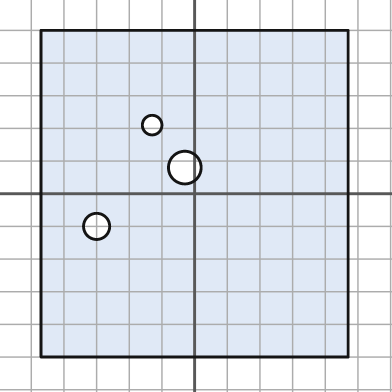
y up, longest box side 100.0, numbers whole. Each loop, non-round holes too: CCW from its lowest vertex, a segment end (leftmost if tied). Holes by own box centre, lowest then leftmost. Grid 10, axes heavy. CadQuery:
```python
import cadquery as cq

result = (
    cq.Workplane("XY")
    .moveTo(-47.0, -50.0)
    .lineTo(47.0, -50.0)
    .lineTo(47.0, 50.0)
    .lineTo(-47.0, 50.0)
    .close()
    .moveTo(-30.0, -10.0)
    .circle(4.0)
    .moveTo(-3.0, 8.0)
    .circle(5.0)
    .moveTo(-13.0, 21.0)
    .circle(3.0)
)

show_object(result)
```